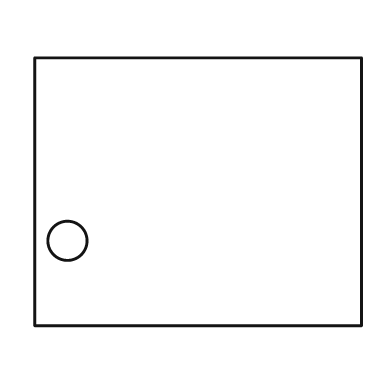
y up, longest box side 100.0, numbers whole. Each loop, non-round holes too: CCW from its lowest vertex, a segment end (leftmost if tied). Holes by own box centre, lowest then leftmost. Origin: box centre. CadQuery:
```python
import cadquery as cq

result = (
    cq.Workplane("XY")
    .moveTo(-50.0, -41.0)
    .lineTo(50.0, -41.0)
    .lineTo(50.0, 41.0)
    .lineTo(-50.0, 41.0)
    .close()
    .moveTo(-40.0, -15.0)
    .circle(6.0)
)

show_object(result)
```